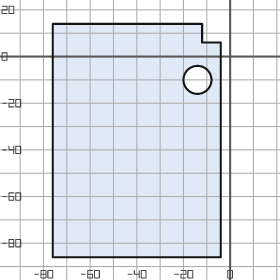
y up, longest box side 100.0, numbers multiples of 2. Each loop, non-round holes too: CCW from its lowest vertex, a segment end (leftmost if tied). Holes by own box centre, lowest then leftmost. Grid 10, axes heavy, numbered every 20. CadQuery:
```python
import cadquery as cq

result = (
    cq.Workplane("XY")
    .moveTo(-76.0, -86.0)
    .lineTo(-4.0, -86.0)
    .lineTo(-4.0, 6.0)
    .lineTo(-12.0, 6.0)
    .lineTo(-12.0, 14.0)
    .lineTo(-76.0, 14.0)
    .close()
    .moveTo(-14.0, -10.0)
    .circle(6.0)
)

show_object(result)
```